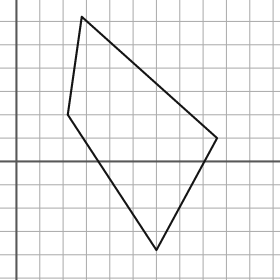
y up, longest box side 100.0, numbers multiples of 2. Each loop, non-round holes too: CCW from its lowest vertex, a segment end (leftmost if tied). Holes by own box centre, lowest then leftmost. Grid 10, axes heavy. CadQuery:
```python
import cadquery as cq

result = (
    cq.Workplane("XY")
    .moveTo(60.0, -38.0)
    .lineTo(86.0, 10.0)
    .lineTo(28.0, 62.0)
    .lineTo(22.0, 20.0)
    .close()
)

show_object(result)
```